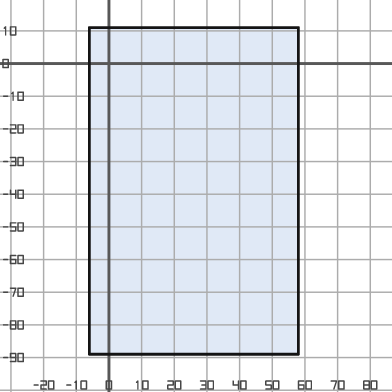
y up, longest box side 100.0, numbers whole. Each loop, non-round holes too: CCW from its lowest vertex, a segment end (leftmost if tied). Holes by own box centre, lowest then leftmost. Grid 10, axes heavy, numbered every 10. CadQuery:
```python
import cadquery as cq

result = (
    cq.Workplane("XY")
    .moveTo(-6.0, -89.0)
    .lineTo(58.0, -89.0)
    .lineTo(58.0, 11.0)
    .lineTo(-6.0, 11.0)
    .close()
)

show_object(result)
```